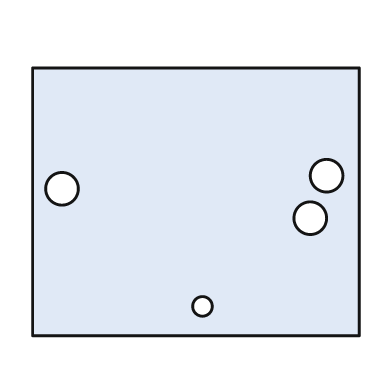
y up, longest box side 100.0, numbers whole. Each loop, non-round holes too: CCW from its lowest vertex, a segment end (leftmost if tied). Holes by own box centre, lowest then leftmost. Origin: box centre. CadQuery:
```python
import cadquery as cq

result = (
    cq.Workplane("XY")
    .moveTo(-50.0, -41.0)
    .lineTo(50.0, -41.0)
    .lineTo(50.0, 41.0)
    .lineTo(-50.0, 41.0)
    .close()
    .moveTo(2.0, -32.0)
    .circle(3.0)
    .moveTo(35.0, -5.0)
    .circle(5.0)
    .moveTo(-41.0, 4.0)
    .circle(5.0)
    .moveTo(40.0, 8.0)
    .circle(5.0)
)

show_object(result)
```